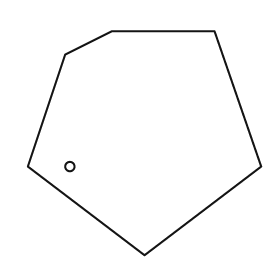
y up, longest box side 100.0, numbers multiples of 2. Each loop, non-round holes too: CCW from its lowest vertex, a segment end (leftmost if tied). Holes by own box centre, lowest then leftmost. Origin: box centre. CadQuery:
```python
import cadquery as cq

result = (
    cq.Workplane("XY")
    .moveTo(0.0, -48.0)
    .lineTo(50.0, -10.0)
    .lineTo(30.0, 48.0)
    .lineTo(-14.0, 48.0)
    .lineTo(-34.0, 38.0)
    .lineTo(-50.0, -10.0)
    .close()
    .moveTo(-32.0, -10.0)
    .circle(2.0)
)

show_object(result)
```